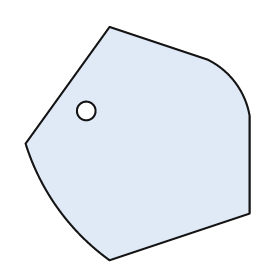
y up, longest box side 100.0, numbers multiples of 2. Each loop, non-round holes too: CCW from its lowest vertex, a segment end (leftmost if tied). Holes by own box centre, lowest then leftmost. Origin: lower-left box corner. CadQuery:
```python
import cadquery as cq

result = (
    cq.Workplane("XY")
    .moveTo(36.0, 0.0)
    .lineTo(96.0, 20.0)
    .lineTo(96.0, 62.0)
    .threePointArc((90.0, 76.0), (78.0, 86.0))
    .lineTo(36.0, 100.0)
    .lineTo(0.0, 50.0)
    .threePointArc((14.0, 22.0), (36.0, 0.0))
    .close()
    .moveTo(26.0, 64.0)
    .circle(4.0)
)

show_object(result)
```